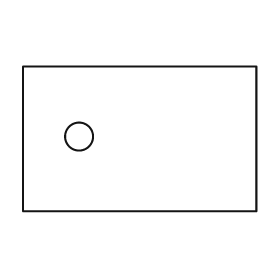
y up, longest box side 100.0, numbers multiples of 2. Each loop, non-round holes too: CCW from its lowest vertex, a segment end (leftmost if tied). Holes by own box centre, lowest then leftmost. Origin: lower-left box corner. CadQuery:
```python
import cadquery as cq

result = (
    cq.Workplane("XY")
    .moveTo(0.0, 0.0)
    .lineTo(100.0, 0.0)
    .lineTo(100.0, 62.0)
    .lineTo(0.0, 62.0)
    .close()
    .moveTo(24.0, 32.0)
    .circle(6.0)
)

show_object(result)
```